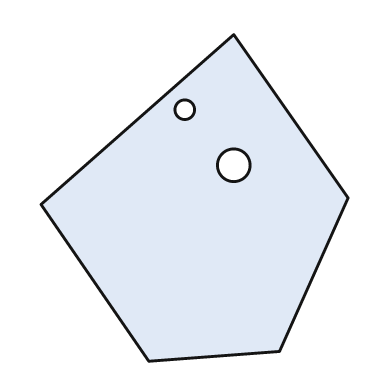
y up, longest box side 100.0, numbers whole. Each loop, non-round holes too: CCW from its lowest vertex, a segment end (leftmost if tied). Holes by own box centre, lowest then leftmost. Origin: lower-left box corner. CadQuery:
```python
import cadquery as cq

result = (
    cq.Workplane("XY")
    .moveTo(33.0, 0.0)
    .lineTo(73.0, 3.0)
    .lineTo(94.0, 50.0)
    .lineTo(59.0, 100.0)
    .lineTo(0.0, 48.0)
    .close()
    .moveTo(59.0, 60.0)
    .circle(5.0)
    .moveTo(44.0, 77.0)
    .circle(3.0)
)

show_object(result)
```